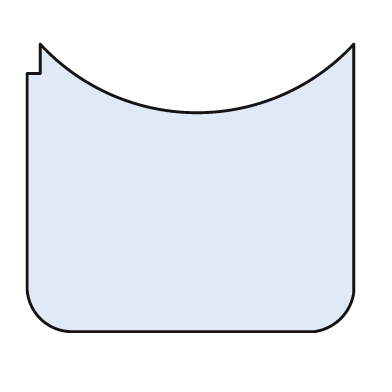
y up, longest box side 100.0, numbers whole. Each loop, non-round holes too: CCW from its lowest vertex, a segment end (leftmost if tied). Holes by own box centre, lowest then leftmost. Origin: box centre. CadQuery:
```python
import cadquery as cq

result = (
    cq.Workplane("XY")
    .moveTo(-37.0, -44.0)
    .lineTo(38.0, -44.0)
    .threePointArc((46.0, -40.0), (50.0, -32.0))
    .lineTo(50.0, 44.0)
    .threePointArc((2.0, 23.0), (-46.0, 44.0))
    .lineTo(-46.0, 35.0)
    .lineTo(-50.0, 35.0)
    .lineTo(-50.0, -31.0)
    .threePointArc((-46.0, -40.0), (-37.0, -44.0))
    .close()
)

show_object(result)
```